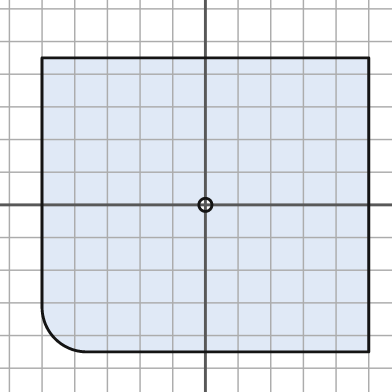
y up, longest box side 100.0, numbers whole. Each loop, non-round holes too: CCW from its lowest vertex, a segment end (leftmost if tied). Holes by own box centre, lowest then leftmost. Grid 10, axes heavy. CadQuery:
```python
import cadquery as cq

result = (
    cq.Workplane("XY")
    .moveTo(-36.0, -45.0)
    .lineTo(50.0, -45.0)
    .lineTo(50.0, 45.0)
    .lineTo(-50.0, 45.0)
    .lineTo(-50.0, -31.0)
    .threePointArc((-46.0, -41.0), (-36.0, -45.0))
    .close()
    .moveTo(0.0, 0.0)
    .circle(2.0)
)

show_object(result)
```